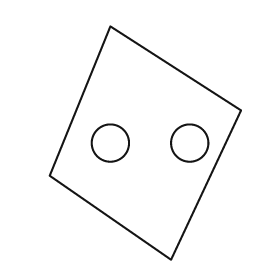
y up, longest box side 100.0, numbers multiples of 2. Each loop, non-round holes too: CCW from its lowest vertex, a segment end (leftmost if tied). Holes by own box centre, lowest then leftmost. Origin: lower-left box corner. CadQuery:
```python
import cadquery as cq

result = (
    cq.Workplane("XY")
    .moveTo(52.0, 0.0)
    .lineTo(82.0, 64.0)
    .lineTo(26.0, 100.0)
    .lineTo(0.0, 36.0)
    .close()
    .moveTo(26.0, 50.0)
    .circle(8.0)
    .moveTo(60.0, 50.0)
    .circle(8.0)
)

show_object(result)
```